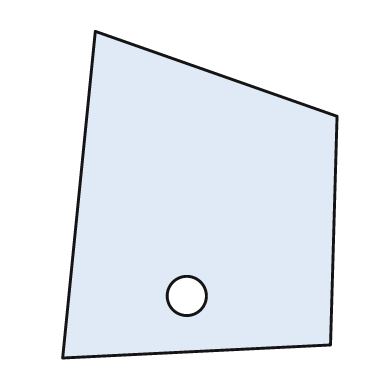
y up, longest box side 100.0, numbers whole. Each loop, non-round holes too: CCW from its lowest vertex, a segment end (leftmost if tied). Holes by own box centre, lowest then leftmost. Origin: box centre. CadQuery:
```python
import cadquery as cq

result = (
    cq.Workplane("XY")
    .moveTo(-42.0, -50.0)
    .lineTo(40.0, -46.0)
    .lineTo(42.0, 24.0)
    .lineTo(-32.0, 50.0)
    .close()
    .moveTo(-4.0, -31.0)
    .circle(6.0)
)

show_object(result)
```